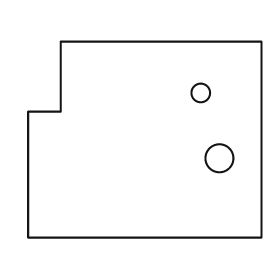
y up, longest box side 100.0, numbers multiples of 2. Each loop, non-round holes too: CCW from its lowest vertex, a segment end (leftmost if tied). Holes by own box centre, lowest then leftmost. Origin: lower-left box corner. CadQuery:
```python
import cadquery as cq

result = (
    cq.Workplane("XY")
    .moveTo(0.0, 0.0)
    .lineTo(100.0, 0.0)
    .lineTo(100.0, 84.0)
    .lineTo(14.0, 84.0)
    .lineTo(14.0, 54.0)
    .lineTo(0.0, 54.0)
    .close()
    .moveTo(82.0, 34.0)
    .circle(6.0)
    .moveTo(74.0, 62.0)
    .circle(4.0)
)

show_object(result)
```